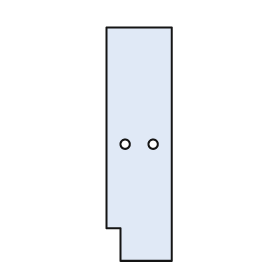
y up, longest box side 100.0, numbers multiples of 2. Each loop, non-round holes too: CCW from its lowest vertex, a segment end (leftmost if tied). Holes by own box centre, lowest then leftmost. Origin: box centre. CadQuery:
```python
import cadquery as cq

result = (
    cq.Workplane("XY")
    .moveTo(-8.0, -50.0)
    .lineTo(14.0, -50.0)
    .lineTo(14.0, 50.0)
    .lineTo(-14.0, 50.0)
    .lineTo(-14.0, -36.0)
    .lineTo(-8.0, -36.0)
    .close()
    .moveTo(-6.0, 0.0)
    .circle(2.0)
    .moveTo(6.0, 0.0)
    .circle(2.0)
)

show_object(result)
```